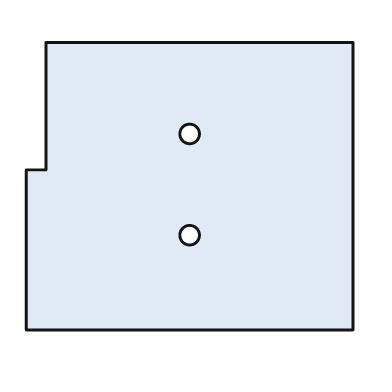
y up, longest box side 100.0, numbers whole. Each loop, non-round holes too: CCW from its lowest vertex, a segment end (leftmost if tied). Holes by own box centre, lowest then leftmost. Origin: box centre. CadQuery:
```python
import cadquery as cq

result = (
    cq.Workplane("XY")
    .moveTo(-50.0, -44.0)
    .lineTo(50.0, -44.0)
    .lineTo(50.0, 44.0)
    .lineTo(-44.0, 44.0)
    .lineTo(-44.0, 5.0)
    .lineTo(-50.0, 5.0)
    .close()
    .moveTo(0.0, -15.0)
    .circle(3.0)
    .moveTo(0.0, 16.0)
    .circle(3.0)
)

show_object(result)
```